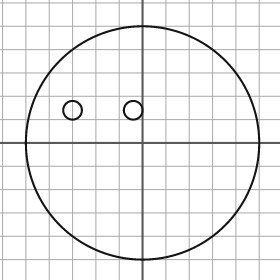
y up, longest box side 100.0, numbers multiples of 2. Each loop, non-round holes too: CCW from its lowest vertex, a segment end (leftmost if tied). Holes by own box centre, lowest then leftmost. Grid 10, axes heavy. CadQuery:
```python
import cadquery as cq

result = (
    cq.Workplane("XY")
    .moveTo(0.0, 0.0)
    .circle(50.0)
    .moveTo(-30.0, 14.0)
    .circle(4.0)
    .moveTo(-4.0, 14.0)
    .circle(4.0)
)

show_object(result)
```